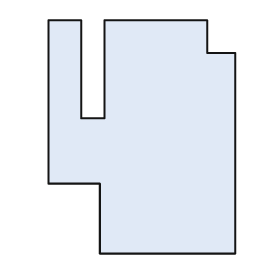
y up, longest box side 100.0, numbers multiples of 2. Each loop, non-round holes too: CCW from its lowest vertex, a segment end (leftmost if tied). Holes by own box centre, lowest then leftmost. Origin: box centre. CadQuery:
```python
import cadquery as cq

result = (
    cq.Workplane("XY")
    .moveTo(-18.0, -50.0)
    .lineTo(40.0, -50.0)
    .lineTo(40.0, 36.0)
    .lineTo(28.0, 36.0)
    .lineTo(28.0, 50.0)
    .lineTo(-16.0, 50.0)
    .lineTo(-16.0, 8.0)
    .lineTo(-26.0, 8.0)
    .lineTo(-26.0, 50.0)
    .lineTo(-40.0, 50.0)
    .lineTo(-40.0, -20.0)
    .lineTo(-18.0, -20.0)
    .close()
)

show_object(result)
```